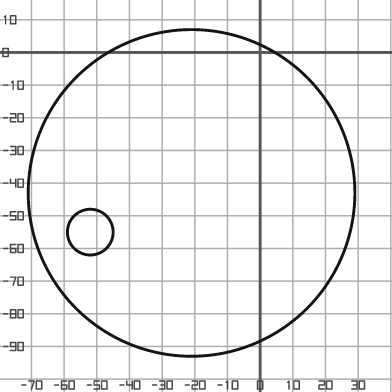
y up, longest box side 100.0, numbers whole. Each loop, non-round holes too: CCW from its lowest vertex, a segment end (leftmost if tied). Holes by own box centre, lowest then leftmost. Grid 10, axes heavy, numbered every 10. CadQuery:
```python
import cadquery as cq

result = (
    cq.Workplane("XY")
    .moveTo(-21.0, -43.0)
    .circle(50.0)
    .moveTo(-52.0, -55.0)
    .circle(7.0)
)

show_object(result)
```